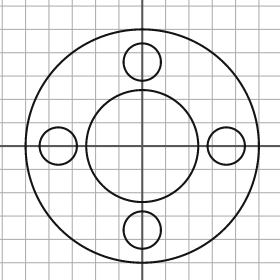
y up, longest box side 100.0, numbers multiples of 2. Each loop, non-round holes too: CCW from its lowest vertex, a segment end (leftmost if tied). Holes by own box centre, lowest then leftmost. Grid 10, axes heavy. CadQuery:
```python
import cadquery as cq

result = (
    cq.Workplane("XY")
    .moveTo(0.0, 0.0)
    .circle(50.0)
    .moveTo(0.0, -36.0)
    .circle(8.0)
    .moveTo(-36.0, 0.0)
    .circle(8.0)
    .moveTo(0.0, 0.0)
    .circle(24.0)
    .moveTo(36.0, 0.0)
    .circle(8.0)
    .moveTo(0.0, 36.0)
    .circle(8.0)
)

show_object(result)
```